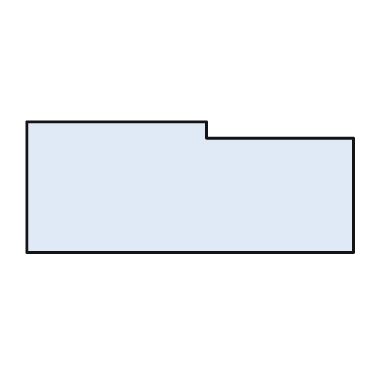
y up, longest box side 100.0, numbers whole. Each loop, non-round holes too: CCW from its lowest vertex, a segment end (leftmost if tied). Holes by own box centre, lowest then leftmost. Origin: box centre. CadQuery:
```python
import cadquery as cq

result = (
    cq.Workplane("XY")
    .moveTo(-50.0, -20.0)
    .lineTo(50.0, -20.0)
    .lineTo(50.0, 15.0)
    .lineTo(5.0, 15.0)
    .lineTo(5.0, 20.0)
    .lineTo(-50.0, 20.0)
    .close()
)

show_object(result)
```